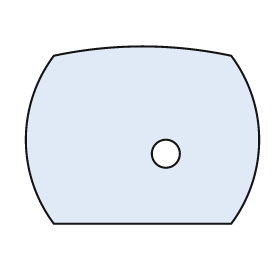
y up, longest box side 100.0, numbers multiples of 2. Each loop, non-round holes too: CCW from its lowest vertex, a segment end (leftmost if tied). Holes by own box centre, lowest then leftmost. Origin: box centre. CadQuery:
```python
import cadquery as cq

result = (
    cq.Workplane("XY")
    .moveTo(-38.0, -38.0)
    .lineTo(38.0, -38.0)
    .threePointArc((50.0, -2.0), (38.0, 34.0))
    .threePointArc((0.0, 38.0), (-38.0, 34.0))
    .threePointArc((-50.0, -2.0), (-38.0, -38.0))
    .close()
    .moveTo(10.0, -8.0)
    .circle(6.0)
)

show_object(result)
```